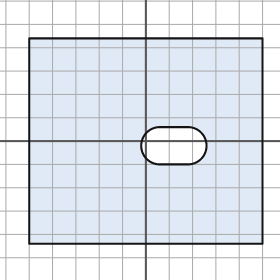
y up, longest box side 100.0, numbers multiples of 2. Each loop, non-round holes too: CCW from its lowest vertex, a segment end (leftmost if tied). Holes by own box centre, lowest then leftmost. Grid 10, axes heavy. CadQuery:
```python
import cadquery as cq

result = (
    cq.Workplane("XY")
    .moveTo(-50.0, -44.0)
    .lineTo(50.0, -44.0)
    .lineTo(50.0, 44.0)
    .lineTo(-50.0, 44.0)
    .close()
    .moveTo(6.0, -10.0)
    .lineTo(18.0, -10.0)
    .threePointArc((26.0, -2.0), (18.0, 6.0))
    .lineTo(6.0, 6.0)
    .threePointArc((-2.0, -2.0), (6.0, -10.0))
    .close()
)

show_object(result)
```